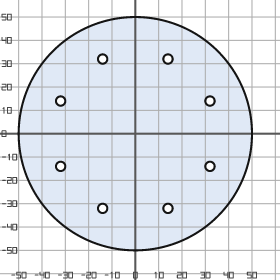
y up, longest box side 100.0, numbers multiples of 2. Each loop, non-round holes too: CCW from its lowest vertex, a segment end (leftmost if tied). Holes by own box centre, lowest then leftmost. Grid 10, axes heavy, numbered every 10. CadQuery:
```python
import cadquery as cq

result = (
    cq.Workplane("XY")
    .moveTo(0.0, 0.0)
    .circle(50.0)
    .moveTo(-14.0, -32.0)
    .circle(2.0)
    .moveTo(14.0, -32.0)
    .circle(2.0)
    .moveTo(-32.0, -14.0)
    .circle(2.0)
    .moveTo(32.0, -14.0)
    .circle(2.0)
    .moveTo(-32.0, 14.0)
    .circle(2.0)
    .moveTo(32.0, 14.0)
    .circle(2.0)
    .moveTo(-14.0, 32.0)
    .circle(2.0)
    .moveTo(14.0, 32.0)
    .circle(2.0)
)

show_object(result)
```